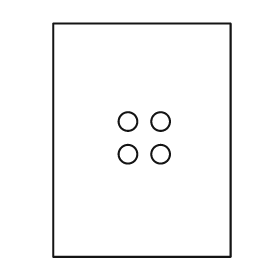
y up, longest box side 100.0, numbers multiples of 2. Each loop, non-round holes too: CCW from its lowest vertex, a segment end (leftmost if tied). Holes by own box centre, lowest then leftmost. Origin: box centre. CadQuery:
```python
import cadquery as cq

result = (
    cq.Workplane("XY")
    .moveTo(-38.0, -50.0)
    .lineTo(38.0, -50.0)
    .lineTo(38.0, 50.0)
    .lineTo(-38.0, 50.0)
    .close()
    .moveTo(-6.0, -6.0)
    .circle(4.0)
    .moveTo(8.0, -6.0)
    .circle(4.0)
    .moveTo(-6.0, 8.0)
    .circle(4.0)
    .moveTo(8.0, 8.0)
    .circle(4.0)
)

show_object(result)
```